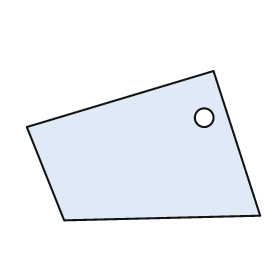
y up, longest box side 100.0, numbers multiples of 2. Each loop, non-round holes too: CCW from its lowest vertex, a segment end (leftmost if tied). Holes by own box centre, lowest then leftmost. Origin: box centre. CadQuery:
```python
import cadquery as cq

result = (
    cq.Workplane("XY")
    .moveTo(-34.0, -32.0)
    .lineTo(50.0, -30.0)
    .lineTo(30.0, 32.0)
    .lineTo(-50.0, 8.0)
    .close()
    .moveTo(26.0, 12.0)
    .circle(4.0)
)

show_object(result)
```